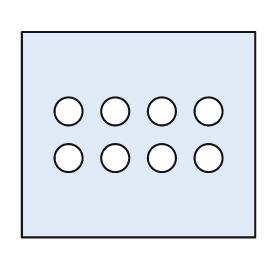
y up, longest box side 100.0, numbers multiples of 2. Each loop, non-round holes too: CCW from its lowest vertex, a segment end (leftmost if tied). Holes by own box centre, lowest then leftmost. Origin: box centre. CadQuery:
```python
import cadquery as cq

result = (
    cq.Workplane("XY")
    .moveTo(-50.0, -44.0)
    .lineTo(50.0, -44.0)
    .lineTo(50.0, 44.0)
    .lineTo(-50.0, 44.0)
    .close()
    .moveTo(-30.0, -10.0)
    .circle(6.0)
    .moveTo(-10.0, -10.0)
    .circle(6.0)
    .moveTo(10.0, -10.0)
    .circle(6.0)
    .moveTo(30.0, -10.0)
    .circle(6.0)
    .moveTo(-30.0, 10.0)
    .circle(6.0)
    .moveTo(-10.0, 10.0)
    .circle(6.0)
    .moveTo(10.0, 10.0)
    .circle(6.0)
    .moveTo(30.0, 10.0)
    .circle(6.0)
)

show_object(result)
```